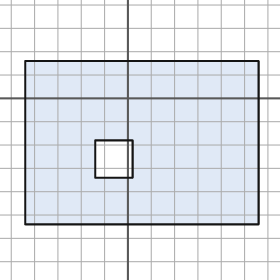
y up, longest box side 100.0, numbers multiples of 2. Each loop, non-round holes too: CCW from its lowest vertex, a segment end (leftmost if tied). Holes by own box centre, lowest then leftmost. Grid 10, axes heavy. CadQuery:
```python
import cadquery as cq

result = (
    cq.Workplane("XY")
    .moveTo(-44.0, -54.0)
    .lineTo(56.0, -54.0)
    .lineTo(56.0, 16.0)
    .lineTo(-44.0, 16.0)
    .close()
    .moveTo(-14.0, -34.0)
    .lineTo(2.0, -34.0)
    .lineTo(2.0, -18.0)
    .lineTo(-14.0, -18.0)
    .close()
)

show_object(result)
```